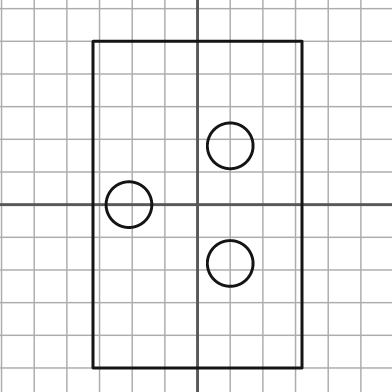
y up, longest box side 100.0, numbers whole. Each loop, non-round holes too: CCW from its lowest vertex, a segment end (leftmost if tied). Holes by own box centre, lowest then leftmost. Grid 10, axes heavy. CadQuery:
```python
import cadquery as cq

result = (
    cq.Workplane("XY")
    .moveTo(-32.0, -50.0)
    .lineTo(32.0, -50.0)
    .lineTo(32.0, 50.0)
    .lineTo(-32.0, 50.0)
    .close()
    .moveTo(10.0, -18.0)
    .circle(7.0)
    .moveTo(-21.0, 0.0)
    .circle(7.0)
    .moveTo(10.0, 18.0)
    .circle(7.0)
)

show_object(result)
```